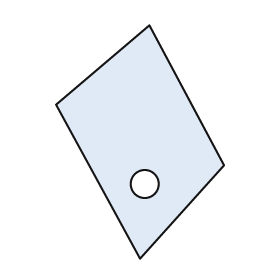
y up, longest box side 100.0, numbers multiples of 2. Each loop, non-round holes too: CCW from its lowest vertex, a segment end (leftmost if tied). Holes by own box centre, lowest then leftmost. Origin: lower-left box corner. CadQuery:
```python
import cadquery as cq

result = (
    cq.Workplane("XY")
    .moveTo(36.0, 0.0)
    .lineTo(72.0, 40.0)
    .lineTo(40.0, 100.0)
    .lineTo(0.0, 66.0)
    .close()
    .moveTo(38.0, 32.0)
    .circle(6.0)
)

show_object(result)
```